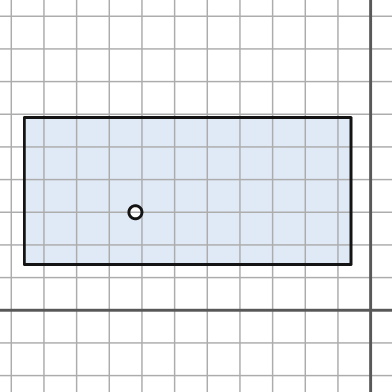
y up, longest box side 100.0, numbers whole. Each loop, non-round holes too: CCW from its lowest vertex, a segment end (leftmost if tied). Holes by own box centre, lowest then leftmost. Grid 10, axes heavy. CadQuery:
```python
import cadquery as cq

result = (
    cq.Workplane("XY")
    .moveTo(-106.0, 14.0)
    .lineTo(-6.0, 14.0)
    .lineTo(-6.0, 59.0)
    .lineTo(-106.0, 59.0)
    .close()
    .moveTo(-72.0, 30.0)
    .circle(2.0)
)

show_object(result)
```